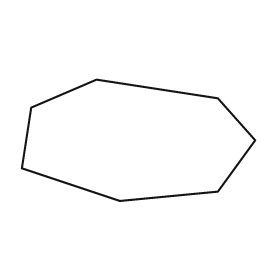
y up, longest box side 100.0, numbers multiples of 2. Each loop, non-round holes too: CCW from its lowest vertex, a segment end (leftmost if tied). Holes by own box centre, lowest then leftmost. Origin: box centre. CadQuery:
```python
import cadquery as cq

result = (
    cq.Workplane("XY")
    .moveTo(-8.0, -26.0)
    .lineTo(34.0, -22.0)
    .lineTo(50.0, 0.0)
    .lineTo(34.0, 18.0)
    .lineTo(-18.0, 26.0)
    .lineTo(-46.0, 14.0)
    .lineTo(-50.0, -12.0)
    .close()
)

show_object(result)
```